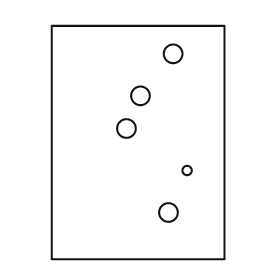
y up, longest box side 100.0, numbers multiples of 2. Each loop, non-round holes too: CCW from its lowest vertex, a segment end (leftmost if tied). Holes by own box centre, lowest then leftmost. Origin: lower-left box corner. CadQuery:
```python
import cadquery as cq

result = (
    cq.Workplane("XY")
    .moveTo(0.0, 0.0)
    .lineTo(74.0, 0.0)
    .lineTo(74.0, 100.0)
    .lineTo(0.0, 100.0)
    .close()
    .moveTo(50.0, 20.0)
    .circle(4.0)
    .moveTo(58.0, 38.0)
    .circle(2.0)
    .moveTo(32.0, 56.0)
    .circle(4.0)
    .moveTo(38.0, 70.0)
    .circle(4.0)
    .moveTo(52.0, 88.0)
    .circle(4.0)
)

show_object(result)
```